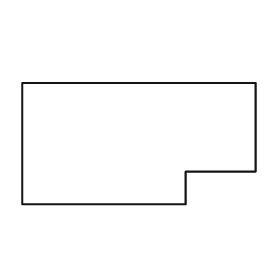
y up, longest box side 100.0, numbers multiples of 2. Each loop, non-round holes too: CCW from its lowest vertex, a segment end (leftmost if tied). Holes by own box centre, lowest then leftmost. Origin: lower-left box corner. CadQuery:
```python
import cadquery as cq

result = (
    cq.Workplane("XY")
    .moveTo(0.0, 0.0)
    .lineTo(70.0, 0.0)
    .lineTo(70.0, 14.0)
    .lineTo(100.0, 14.0)
    .lineTo(100.0, 52.0)
    .lineTo(0.0, 52.0)
    .close()
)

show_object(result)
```